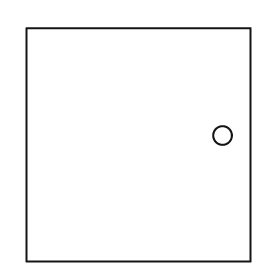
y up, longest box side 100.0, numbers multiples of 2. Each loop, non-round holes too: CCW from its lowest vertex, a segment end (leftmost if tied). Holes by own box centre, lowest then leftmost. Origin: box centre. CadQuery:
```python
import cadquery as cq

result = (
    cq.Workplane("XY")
    .moveTo(-48.0, -50.0)
    .lineTo(48.0, -50.0)
    .lineTo(48.0, 50.0)
    .lineTo(-48.0, 50.0)
    .close()
    .moveTo(36.0, 4.0)
    .circle(4.0)
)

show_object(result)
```